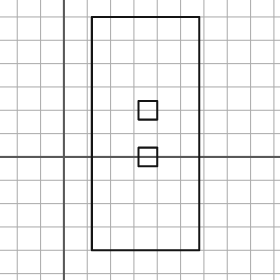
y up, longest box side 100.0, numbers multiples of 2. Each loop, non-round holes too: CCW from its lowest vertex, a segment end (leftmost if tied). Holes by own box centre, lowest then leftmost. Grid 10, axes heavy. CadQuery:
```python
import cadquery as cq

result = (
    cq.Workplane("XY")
    .moveTo(12.0, -40.0)
    .lineTo(58.0, -40.0)
    .lineTo(58.0, 60.0)
    .lineTo(12.0, 60.0)
    .close()
    .moveTo(32.0, -4.0)
    .lineTo(40.0, -4.0)
    .lineTo(40.0, 4.0)
    .lineTo(32.0, 4.0)
    .close()
    .moveTo(32.0, 16.0)
    .lineTo(40.0, 16.0)
    .lineTo(40.0, 24.0)
    .lineTo(32.0, 24.0)
    .close()
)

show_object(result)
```